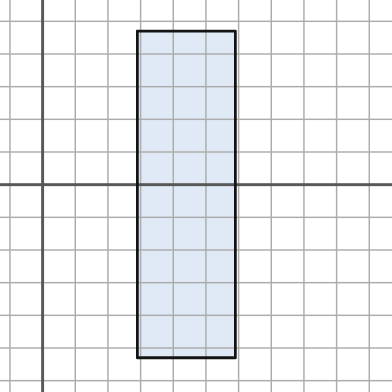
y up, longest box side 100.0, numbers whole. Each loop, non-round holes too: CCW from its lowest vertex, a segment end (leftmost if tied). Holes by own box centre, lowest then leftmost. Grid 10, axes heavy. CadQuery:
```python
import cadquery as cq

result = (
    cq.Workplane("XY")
    .moveTo(29.0, -53.0)
    .lineTo(59.0, -53.0)
    .lineTo(59.0, 47.0)
    .lineTo(29.0, 47.0)
    .close()
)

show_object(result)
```